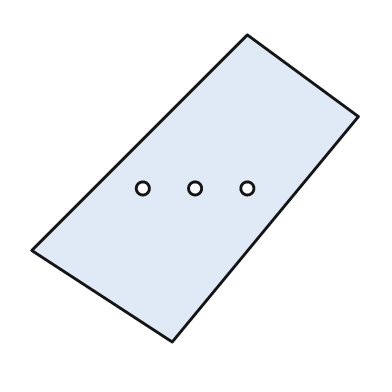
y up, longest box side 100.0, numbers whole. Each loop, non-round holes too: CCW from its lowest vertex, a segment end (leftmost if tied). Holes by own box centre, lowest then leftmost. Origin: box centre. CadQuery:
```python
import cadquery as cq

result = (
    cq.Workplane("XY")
    .moveTo(-7.0, -47.0)
    .lineTo(50.0, 22.0)
    .lineTo(16.0, 47.0)
    .lineTo(-50.0, -19.0)
    .close()
    .moveTo(-16.0, 0.0)
    .circle(2.0)
    .moveTo(0.0, 0.0)
    .circle(2.0)
    .moveTo(16.0, 0.0)
    .circle(2.0)
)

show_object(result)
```